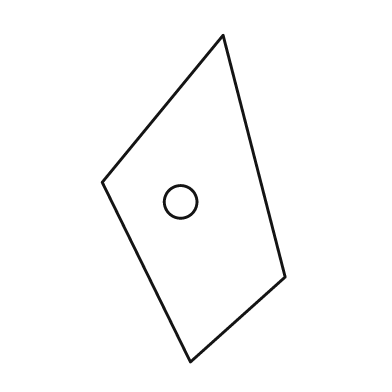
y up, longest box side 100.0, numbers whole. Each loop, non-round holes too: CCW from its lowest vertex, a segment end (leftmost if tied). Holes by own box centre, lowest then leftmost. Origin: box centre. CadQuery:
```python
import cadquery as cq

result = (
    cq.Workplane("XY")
    .moveTo(-1.0, -50.0)
    .lineTo(28.0, -24.0)
    .lineTo(9.0, 50.0)
    .lineTo(-28.0, 5.0)
    .close()
    .moveTo(-4.0, -1.0)
    .circle(5.0)
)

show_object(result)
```